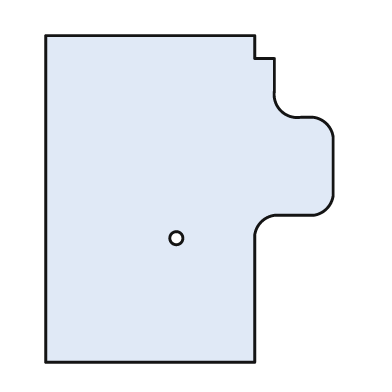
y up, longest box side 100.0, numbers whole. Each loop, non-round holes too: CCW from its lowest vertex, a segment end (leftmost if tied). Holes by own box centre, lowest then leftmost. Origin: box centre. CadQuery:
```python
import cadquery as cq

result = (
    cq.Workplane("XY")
    .moveTo(-44.0, -50.0)
    .lineTo(20.0, -50.0)
    .lineTo(20.0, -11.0)
    .threePointArc((22.0, -7.0), (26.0, -5.0))
    .lineTo(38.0, -5.0)
    .threePointArc((42.0, -3.0), (44.0, 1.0))
    .lineTo(44.0, 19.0)
    .threePointArc((42.0, 23.0), (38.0, 25.0))
    .lineTo(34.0, 25.0)
    .threePointArc((28.0, 27.0), (26.0, 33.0))
    .lineTo(26.0, 43.0)
    .lineTo(20.0, 43.0)
    .lineTo(20.0, 50.0)
    .lineTo(-44.0, 50.0)
    .close()
    .moveTo(-4.0, -12.0)
    .circle(2.0)
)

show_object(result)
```